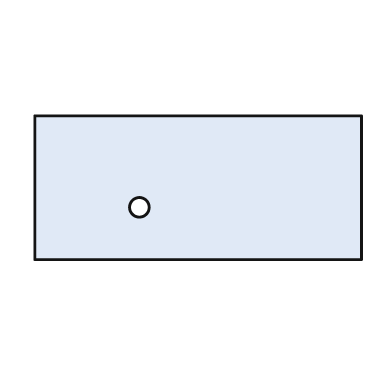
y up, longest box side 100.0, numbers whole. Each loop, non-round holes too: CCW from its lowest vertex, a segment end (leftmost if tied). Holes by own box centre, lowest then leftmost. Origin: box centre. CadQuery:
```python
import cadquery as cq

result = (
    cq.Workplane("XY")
    .moveTo(-50.0, -22.0)
    .lineTo(50.0, -22.0)
    .lineTo(50.0, 22.0)
    .lineTo(-50.0, 22.0)
    .close()
    .moveTo(-18.0, -6.0)
    .circle(3.0)
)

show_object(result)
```